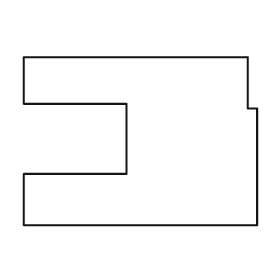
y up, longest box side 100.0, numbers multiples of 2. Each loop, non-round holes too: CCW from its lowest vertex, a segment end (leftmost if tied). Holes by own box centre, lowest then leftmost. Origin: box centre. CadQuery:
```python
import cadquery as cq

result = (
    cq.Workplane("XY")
    .moveTo(-50.0, -36.0)
    .lineTo(50.0, -36.0)
    .lineTo(50.0, 14.0)
    .lineTo(46.0, 14.0)
    .lineTo(46.0, 36.0)
    .lineTo(-50.0, 36.0)
    .lineTo(-50.0, 16.0)
    .lineTo(-6.0, 16.0)
    .lineTo(-6.0, -14.0)
    .lineTo(-50.0, -14.0)
    .close()
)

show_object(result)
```